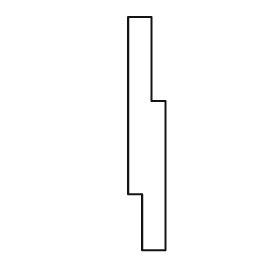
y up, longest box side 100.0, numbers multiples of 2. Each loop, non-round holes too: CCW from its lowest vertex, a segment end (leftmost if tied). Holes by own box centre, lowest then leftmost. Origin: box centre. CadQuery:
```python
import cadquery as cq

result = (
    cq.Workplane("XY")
    .moveTo(-2.0, -50.0)
    .lineTo(8.0, -50.0)
    .lineTo(8.0, 14.0)
    .lineTo(2.0, 14.0)
    .lineTo(2.0, 50.0)
    .lineTo(-8.0, 50.0)
    .lineTo(-8.0, -26.0)
    .lineTo(-2.0, -26.0)
    .close()
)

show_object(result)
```